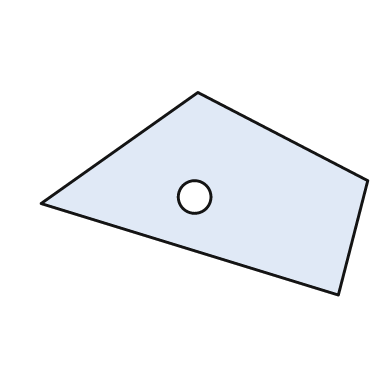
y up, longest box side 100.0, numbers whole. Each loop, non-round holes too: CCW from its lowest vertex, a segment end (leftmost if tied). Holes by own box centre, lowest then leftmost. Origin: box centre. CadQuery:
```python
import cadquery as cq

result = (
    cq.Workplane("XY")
    .moveTo(41.0, -31.0)
    .lineTo(50.0, 4.0)
    .lineTo(-2.0, 31.0)
    .lineTo(-50.0, -3.0)
    .close()
    .moveTo(-3.0, -1.0)
    .circle(5.0)
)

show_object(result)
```